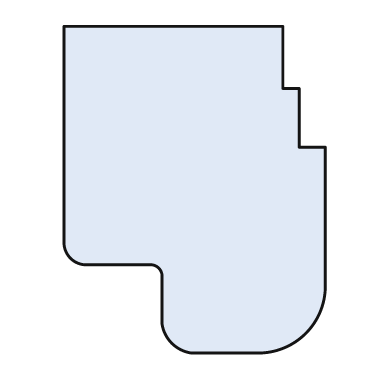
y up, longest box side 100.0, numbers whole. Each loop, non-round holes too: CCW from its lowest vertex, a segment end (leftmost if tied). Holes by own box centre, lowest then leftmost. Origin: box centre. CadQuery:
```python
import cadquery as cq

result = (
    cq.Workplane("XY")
    .moveTo(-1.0, -50.0)
    .lineTo(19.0, -50.0)
    .threePointArc((34.0, -44.0), (40.0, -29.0))
    .lineTo(40.0, 13.0)
    .lineTo(32.0, 13.0)
    .lineTo(32.0, 31.0)
    .lineTo(27.0, 31.0)
    .lineTo(27.0, 50.0)
    .lineTo(-40.0, 50.0)
    .lineTo(-40.0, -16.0)
    .threePointArc((-38.0, -21.0), (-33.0, -23.0))
    .lineTo(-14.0, -23.0)
    .threePointArc((-11.0, -24.0), (-10.0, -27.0))
    .lineTo(-10.0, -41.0)
    .threePointArc((-7.0, -47.0), (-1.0, -50.0))
    .close()
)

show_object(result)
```